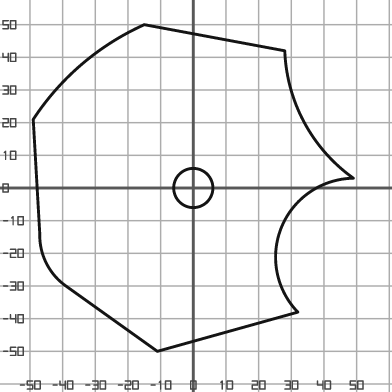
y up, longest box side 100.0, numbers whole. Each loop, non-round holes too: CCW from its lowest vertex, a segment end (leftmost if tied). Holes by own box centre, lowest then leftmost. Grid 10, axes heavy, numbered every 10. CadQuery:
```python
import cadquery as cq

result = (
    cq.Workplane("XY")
    .moveTo(-11.0, -50.0)
    .lineTo(32.0, -38.0)
    .threePointArc((27.0, -12.0), (49.0, 3.0))
    .threePointArc((34.0, 20.0), (28.0, 42.0))
    .lineTo(-15.0, 50.0)
    .threePointArc((-34.0, 38.0), (-49.0, 21.0))
    .lineTo(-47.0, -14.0)
    .threePointArc((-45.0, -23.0), (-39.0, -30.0))
    .close()
    .moveTo(0.0, 0.0)
    .circle(6.0)
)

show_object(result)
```